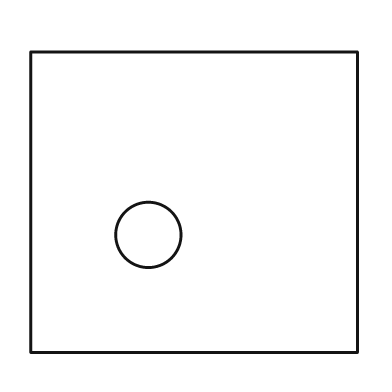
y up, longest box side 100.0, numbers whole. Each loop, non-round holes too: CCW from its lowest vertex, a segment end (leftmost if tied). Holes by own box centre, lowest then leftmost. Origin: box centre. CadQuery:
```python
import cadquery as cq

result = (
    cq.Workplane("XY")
    .moveTo(-50.0, -46.0)
    .lineTo(50.0, -46.0)
    .lineTo(50.0, 46.0)
    .lineTo(-50.0, 46.0)
    .close()
    .moveTo(-14.0, -10.0)
    .circle(10.0)
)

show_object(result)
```